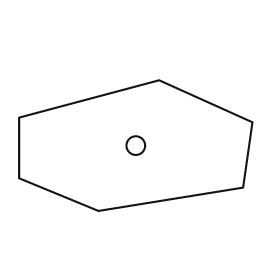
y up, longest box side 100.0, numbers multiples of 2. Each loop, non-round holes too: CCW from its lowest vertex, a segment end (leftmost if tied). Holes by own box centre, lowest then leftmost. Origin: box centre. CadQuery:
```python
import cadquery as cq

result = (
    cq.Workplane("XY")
    .moveTo(-16.0, -28.0)
    .lineTo(46.0, -18.0)
    .lineTo(50.0, 10.0)
    .lineTo(10.0, 28.0)
    .lineTo(-50.0, 12.0)
    .lineTo(-50.0, -14.0)
    .close()
    .moveTo(0.0, 0.0)
    .circle(4.0)
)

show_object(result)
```